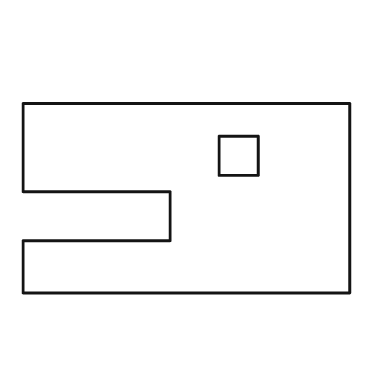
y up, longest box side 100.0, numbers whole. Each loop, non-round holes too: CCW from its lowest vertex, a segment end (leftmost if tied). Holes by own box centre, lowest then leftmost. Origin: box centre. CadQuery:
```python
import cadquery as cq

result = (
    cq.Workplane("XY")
    .moveTo(-50.0, -29.0)
    .lineTo(50.0, -29.0)
    .lineTo(50.0, 29.0)
    .lineTo(-50.0, 29.0)
    .lineTo(-50.0, 2.0)
    .lineTo(-5.0, 2.0)
    .lineTo(-5.0, -13.0)
    .lineTo(-50.0, -13.0)
    .close()
    .moveTo(10.0, 7.0)
    .lineTo(22.0, 7.0)
    .lineTo(22.0, 19.0)
    .lineTo(10.0, 19.0)
    .close()
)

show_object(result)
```